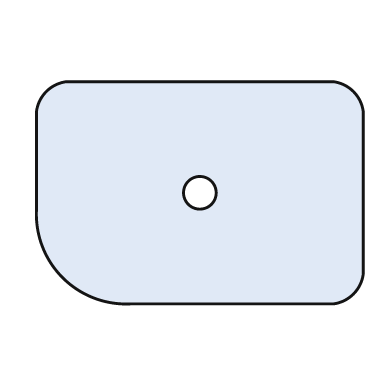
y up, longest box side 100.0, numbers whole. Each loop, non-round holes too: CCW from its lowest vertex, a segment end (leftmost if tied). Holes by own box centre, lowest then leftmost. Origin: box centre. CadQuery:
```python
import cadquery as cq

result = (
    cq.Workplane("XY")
    .moveTo(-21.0, -34.0)
    .lineTo(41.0, -34.0)
    .threePointArc((47.0, -31.0), (50.0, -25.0))
    .lineTo(50.0, 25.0)
    .threePointArc((47.0, 31.0), (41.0, 34.0))
    .lineTo(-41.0, 34.0)
    .threePointArc((-47.0, 31.0), (-50.0, 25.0))
    .lineTo(-50.0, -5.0)
    .threePointArc((-42.0, -26.0), (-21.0, -34.0))
    .close()
    .moveTo(0.0, 0.0)
    .circle(5.0)
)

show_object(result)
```